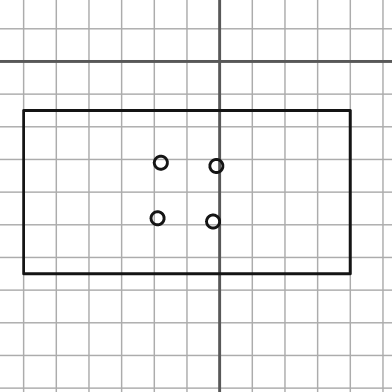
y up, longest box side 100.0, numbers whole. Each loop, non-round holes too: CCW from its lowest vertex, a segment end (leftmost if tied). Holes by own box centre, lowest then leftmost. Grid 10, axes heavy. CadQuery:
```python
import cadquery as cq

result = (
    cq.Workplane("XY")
    .moveTo(-60.0, -65.0)
    .lineTo(40.0, -65.0)
    .lineTo(40.0, -15.0)
    .lineTo(-60.0, -15.0)
    .close()
    .moveTo(-2.0, -49.0)
    .circle(2.0)
    .moveTo(-19.0, -48.0)
    .circle(2.0)
    .moveTo(-1.0, -32.0)
    .circle(2.0)
    .moveTo(-18.0, -31.0)
    .circle(2.0)
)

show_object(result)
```